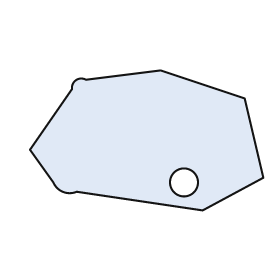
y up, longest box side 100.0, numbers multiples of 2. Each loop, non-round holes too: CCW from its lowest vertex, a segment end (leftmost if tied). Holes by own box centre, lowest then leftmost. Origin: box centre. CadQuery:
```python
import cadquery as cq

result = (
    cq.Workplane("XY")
    .moveTo(24.0, -30.0)
    .lineTo(50.0, -16.0)
    .lineTo(42.0, 18.0)
    .lineTo(6.0, 30.0)
    .lineTo(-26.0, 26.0)
    .threePointArc((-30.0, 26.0), (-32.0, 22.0))
    .lineTo(-50.0, -4.0)
    .lineTo(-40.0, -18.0)
    .threePointArc((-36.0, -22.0), (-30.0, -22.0))
    .close()
    .moveTo(16.0, -18.0)
    .circle(6.0)
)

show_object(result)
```